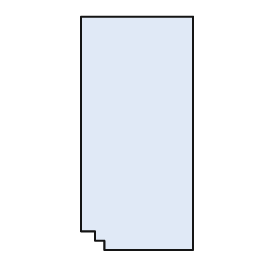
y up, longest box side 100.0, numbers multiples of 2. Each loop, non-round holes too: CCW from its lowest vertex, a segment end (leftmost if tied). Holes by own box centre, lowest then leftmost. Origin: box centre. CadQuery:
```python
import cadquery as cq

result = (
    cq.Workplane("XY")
    .moveTo(-14.0, -50.0)
    .lineTo(24.0, -50.0)
    .lineTo(24.0, 50.0)
    .lineTo(-24.0, 50.0)
    .lineTo(-24.0, -42.0)
    .lineTo(-18.0, -42.0)
    .lineTo(-18.0, -46.0)
    .lineTo(-14.0, -46.0)
    .close()
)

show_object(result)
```